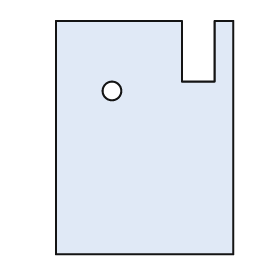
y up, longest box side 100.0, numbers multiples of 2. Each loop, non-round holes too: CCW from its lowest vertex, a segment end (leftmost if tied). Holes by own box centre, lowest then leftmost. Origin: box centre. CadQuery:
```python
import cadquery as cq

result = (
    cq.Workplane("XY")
    .moveTo(-38.0, -50.0)
    .lineTo(38.0, -50.0)
    .lineTo(38.0, 50.0)
    .lineTo(30.0, 50.0)
    .lineTo(30.0, 24.0)
    .lineTo(16.0, 24.0)
    .lineTo(16.0, 50.0)
    .lineTo(-38.0, 50.0)
    .close()
    .moveTo(-14.0, 20.0)
    .circle(4.0)
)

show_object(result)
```